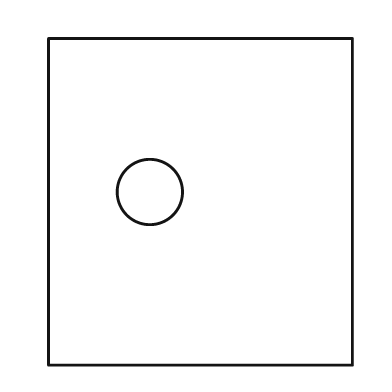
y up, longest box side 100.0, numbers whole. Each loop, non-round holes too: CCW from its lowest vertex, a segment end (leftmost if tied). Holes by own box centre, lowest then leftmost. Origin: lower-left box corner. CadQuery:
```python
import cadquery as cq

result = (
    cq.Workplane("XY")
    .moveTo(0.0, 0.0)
    .lineTo(93.0, 0.0)
    .lineTo(93.0, 100.0)
    .lineTo(0.0, 100.0)
    .close()
    .moveTo(31.0, 53.0)
    .circle(10.0)
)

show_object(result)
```